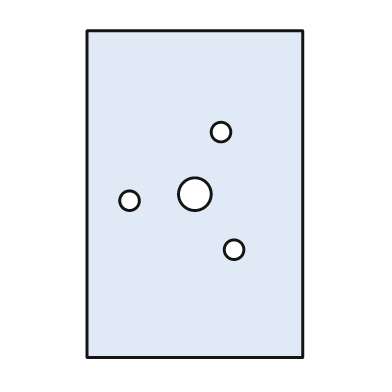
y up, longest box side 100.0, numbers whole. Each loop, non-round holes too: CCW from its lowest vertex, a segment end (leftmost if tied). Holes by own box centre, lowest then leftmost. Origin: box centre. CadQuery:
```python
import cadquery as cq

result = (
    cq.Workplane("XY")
    .moveTo(-33.0, -50.0)
    .lineTo(33.0, -50.0)
    .lineTo(33.0, 50.0)
    .lineTo(-33.0, 50.0)
    .close()
    .moveTo(12.0, -17.0)
    .circle(3.0)
    .moveTo(-20.0, -2.0)
    .circle(3.0)
    .moveTo(0.0, 0.0)
    .circle(5.0)
    .moveTo(8.0, 19.0)
    .circle(3.0)
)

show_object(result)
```